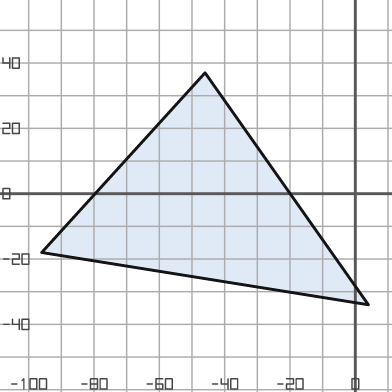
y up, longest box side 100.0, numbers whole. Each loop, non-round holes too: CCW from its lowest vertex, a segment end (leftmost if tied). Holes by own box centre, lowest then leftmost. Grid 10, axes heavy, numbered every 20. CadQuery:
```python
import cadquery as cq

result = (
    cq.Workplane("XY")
    .moveTo(4.0, -34.0)
    .lineTo(-46.0, 37.0)
    .lineTo(-96.0, -18.0)
    .close()
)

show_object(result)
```